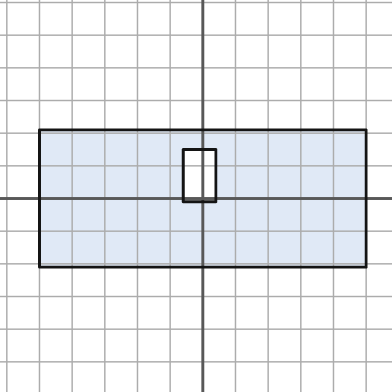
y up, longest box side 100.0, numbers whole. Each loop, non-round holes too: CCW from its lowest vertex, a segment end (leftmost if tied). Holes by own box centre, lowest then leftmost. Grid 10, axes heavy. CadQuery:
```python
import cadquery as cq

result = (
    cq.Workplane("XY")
    .moveTo(-50.0, -21.0)
    .lineTo(50.0, -21.0)
    .lineTo(50.0, 21.0)
    .lineTo(-50.0, 21.0)
    .close()
    .moveTo(-6.0, -1.0)
    .lineTo(4.0, -1.0)
    .lineTo(4.0, 15.0)
    .lineTo(-6.0, 15.0)
    .close()
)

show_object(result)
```